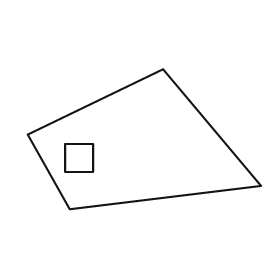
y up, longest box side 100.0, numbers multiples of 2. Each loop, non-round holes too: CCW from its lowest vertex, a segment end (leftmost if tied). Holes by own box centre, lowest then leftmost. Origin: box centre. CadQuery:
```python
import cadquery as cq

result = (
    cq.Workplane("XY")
    .moveTo(-32.0, -30.0)
    .lineTo(50.0, -20.0)
    .lineTo(8.0, 30.0)
    .lineTo(-50.0, 2.0)
    .close()
    .moveTo(-34.0, -14.0)
    .lineTo(-22.0, -14.0)
    .lineTo(-22.0, -2.0)
    .lineTo(-34.0, -2.0)
    .close()
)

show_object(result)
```